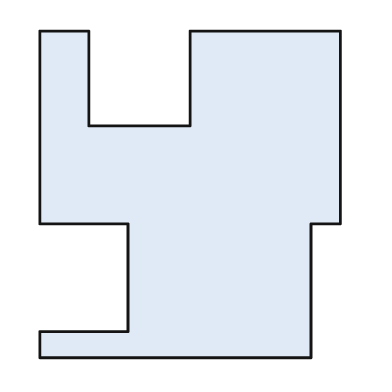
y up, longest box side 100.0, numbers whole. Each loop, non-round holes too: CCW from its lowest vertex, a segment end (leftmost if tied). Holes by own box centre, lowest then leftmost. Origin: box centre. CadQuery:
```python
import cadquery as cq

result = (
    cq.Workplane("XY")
    .moveTo(-46.0, -50.0)
    .lineTo(37.0, -50.0)
    .lineTo(37.0, -9.0)
    .lineTo(46.0, -9.0)
    .lineTo(46.0, 50.0)
    .lineTo(0.0, 50.0)
    .lineTo(0.0, 21.0)
    .lineTo(-31.0, 21.0)
    .lineTo(-31.0, 50.0)
    .lineTo(-46.0, 50.0)
    .lineTo(-46.0, -9.0)
    .lineTo(-19.0, -9.0)
    .lineTo(-19.0, -42.0)
    .lineTo(-46.0, -42.0)
    .close()
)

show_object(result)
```